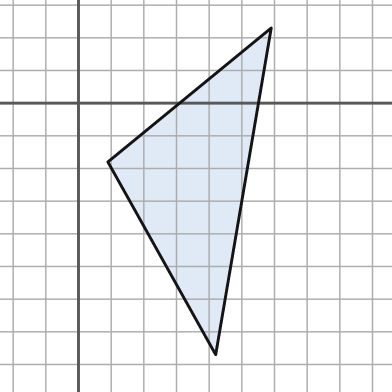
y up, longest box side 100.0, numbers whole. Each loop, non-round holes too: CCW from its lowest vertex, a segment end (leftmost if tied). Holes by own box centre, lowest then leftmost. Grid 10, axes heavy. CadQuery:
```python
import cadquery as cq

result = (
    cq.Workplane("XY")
    .moveTo(42.0, -77.0)
    .lineTo(59.0, 23.0)
    .lineTo(9.0, -18.0)
    .close()
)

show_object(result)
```